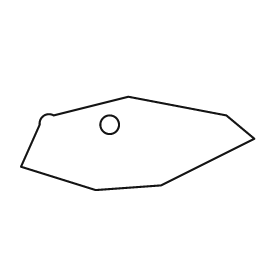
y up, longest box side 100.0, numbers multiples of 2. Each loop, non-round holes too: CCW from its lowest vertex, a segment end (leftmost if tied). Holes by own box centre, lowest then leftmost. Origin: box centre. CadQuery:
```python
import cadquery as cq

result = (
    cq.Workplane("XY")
    .moveTo(-18.0, -20.0)
    .lineTo(10.0, -18.0)
    .lineTo(50.0, 2.0)
    .lineTo(38.0, 12.0)
    .lineTo(-4.0, 20.0)
    .lineTo(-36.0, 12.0)
    .threePointArc((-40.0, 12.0), (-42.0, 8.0))
    .lineTo(-50.0, -10.0)
    .close()
    .moveTo(-12.0, 8.0)
    .circle(4.0)
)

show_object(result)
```